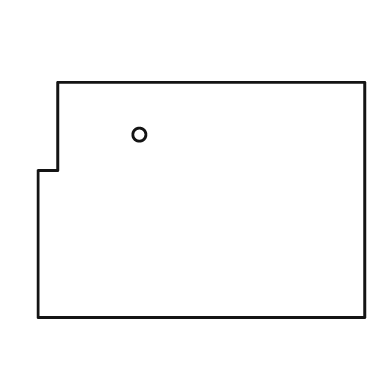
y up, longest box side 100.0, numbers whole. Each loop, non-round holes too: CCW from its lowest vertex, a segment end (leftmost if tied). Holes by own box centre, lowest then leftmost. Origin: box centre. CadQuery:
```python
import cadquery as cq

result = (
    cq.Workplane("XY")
    .moveTo(-50.0, -36.0)
    .lineTo(50.0, -36.0)
    .lineTo(50.0, 36.0)
    .lineTo(-44.0, 36.0)
    .lineTo(-44.0, 9.0)
    .lineTo(-50.0, 9.0)
    .close()
    .moveTo(-19.0, 20.0)
    .circle(2.0)
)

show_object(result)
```